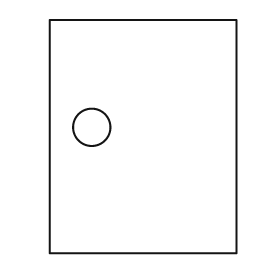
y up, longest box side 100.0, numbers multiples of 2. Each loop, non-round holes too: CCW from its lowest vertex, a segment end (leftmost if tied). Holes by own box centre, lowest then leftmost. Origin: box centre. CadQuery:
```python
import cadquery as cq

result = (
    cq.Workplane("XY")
    .moveTo(-40.0, -50.0)
    .lineTo(40.0, -50.0)
    .lineTo(40.0, 50.0)
    .lineTo(-40.0, 50.0)
    .close()
    .moveTo(-22.0, 4.0)
    .circle(8.0)
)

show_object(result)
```